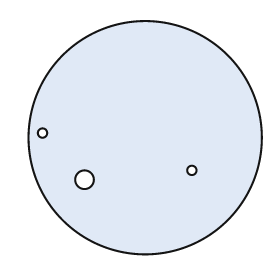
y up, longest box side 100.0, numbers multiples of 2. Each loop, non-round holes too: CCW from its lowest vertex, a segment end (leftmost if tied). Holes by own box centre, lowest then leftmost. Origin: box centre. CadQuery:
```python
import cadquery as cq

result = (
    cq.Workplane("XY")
    .moveTo(0.0, 0.0)
    .circle(50.0)
    .moveTo(-26.0, -18.0)
    .circle(4.0)
    .moveTo(20.0, -14.0)
    .circle(2.0)
    .moveTo(-44.0, 2.0)
    .circle(2.0)
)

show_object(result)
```